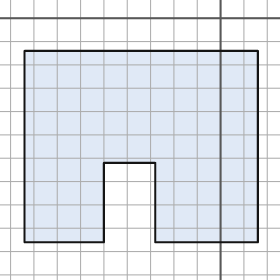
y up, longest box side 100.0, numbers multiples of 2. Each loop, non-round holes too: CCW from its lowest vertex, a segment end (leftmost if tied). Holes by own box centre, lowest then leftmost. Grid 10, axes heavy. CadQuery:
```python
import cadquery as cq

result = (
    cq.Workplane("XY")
    .moveTo(-84.0, -96.0)
    .lineTo(-50.0, -96.0)
    .lineTo(-50.0, -62.0)
    .lineTo(-28.0, -62.0)
    .lineTo(-28.0, -96.0)
    .lineTo(16.0, -96.0)
    .lineTo(16.0, -14.0)
    .lineTo(-84.0, -14.0)
    .close()
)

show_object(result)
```